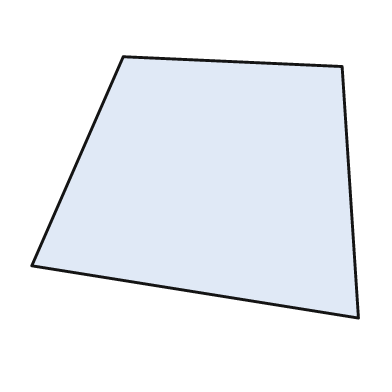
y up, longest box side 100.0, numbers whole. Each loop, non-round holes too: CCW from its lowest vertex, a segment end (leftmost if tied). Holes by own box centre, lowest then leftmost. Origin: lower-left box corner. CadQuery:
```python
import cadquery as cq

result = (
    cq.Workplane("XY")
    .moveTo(100.0, 0.0)
    .lineTo(95.0, 77.0)
    .lineTo(28.0, 80.0)
    .lineTo(0.0, 16.0)
    .close()
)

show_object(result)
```